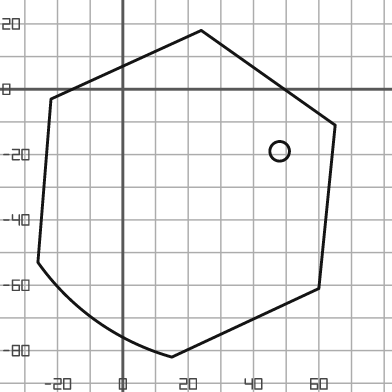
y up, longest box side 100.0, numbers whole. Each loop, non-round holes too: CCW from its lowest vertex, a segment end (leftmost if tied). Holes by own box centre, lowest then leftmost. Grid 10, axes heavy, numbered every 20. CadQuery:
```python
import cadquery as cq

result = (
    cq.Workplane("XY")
    .moveTo(15.0, -82.0)
    .lineTo(60.0, -61.0)
    .lineTo(65.0, -11.0)
    .lineTo(24.0, 18.0)
    .lineTo(-22.0, -3.0)
    .lineTo(-26.0, -53.0)
    .threePointArc((-8.0, -71.0), (15.0, -82.0))
    .close()
    .moveTo(48.0, -19.0)
    .circle(3.0)
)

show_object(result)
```